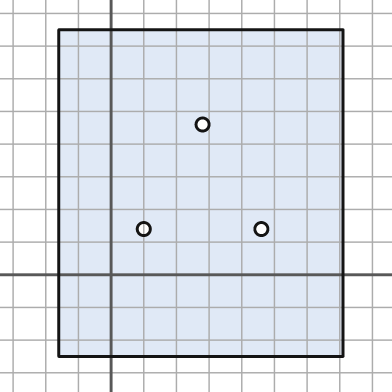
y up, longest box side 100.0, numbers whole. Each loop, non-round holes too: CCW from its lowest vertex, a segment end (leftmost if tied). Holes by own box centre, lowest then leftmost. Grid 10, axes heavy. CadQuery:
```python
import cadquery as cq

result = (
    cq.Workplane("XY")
    .moveTo(-16.0, -25.0)
    .lineTo(71.0, -25.0)
    .lineTo(71.0, 75.0)
    .lineTo(-16.0, 75.0)
    .close()
    .moveTo(10.0, 14.0)
    .circle(2.0)
    .moveTo(46.0, 14.0)
    .circle(2.0)
    .moveTo(28.0, 46.0)
    .circle(2.0)
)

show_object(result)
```